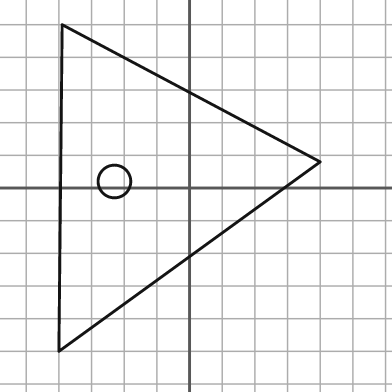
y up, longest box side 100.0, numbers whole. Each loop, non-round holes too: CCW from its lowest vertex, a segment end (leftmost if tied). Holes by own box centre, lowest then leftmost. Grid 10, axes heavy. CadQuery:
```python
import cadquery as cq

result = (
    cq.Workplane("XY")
    .moveTo(-40.0, -50.0)
    .lineTo(40.0, 8.0)
    .lineTo(-39.0, 50.0)
    .close()
    .moveTo(-23.0, 2.0)
    .circle(5.0)
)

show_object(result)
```